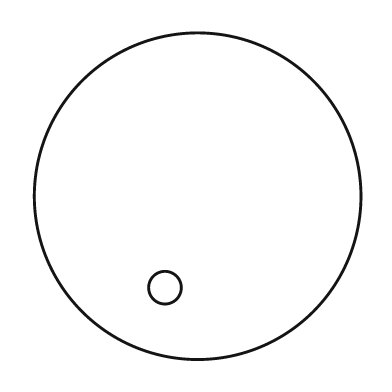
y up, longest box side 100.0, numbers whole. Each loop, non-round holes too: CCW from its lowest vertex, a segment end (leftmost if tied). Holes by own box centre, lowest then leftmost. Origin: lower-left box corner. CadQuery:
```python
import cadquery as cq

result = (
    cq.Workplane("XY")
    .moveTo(50.0, 50.0)
    .circle(50.0)
    .moveTo(40.0, 22.0)
    .circle(5.0)
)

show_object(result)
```